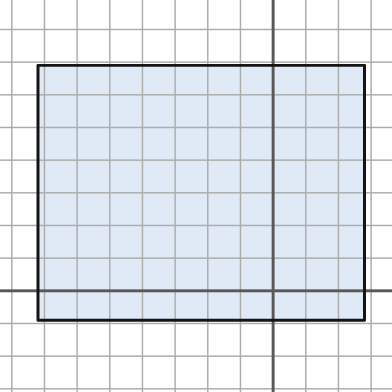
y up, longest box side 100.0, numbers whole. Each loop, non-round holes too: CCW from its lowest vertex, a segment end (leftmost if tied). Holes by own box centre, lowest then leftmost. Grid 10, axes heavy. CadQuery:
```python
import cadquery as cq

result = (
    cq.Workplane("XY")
    .moveTo(-72.0, -9.0)
    .lineTo(28.0, -9.0)
    .lineTo(28.0, 69.0)
    .lineTo(-72.0, 69.0)
    .close()
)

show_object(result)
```